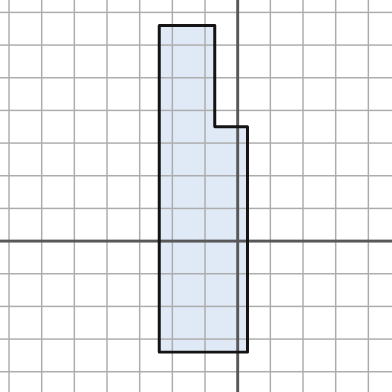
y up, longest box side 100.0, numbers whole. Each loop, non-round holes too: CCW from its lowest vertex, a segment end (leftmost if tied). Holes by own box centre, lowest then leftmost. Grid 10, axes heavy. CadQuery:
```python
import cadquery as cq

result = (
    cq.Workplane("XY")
    .moveTo(-24.0, -34.0)
    .lineTo(3.0, -34.0)
    .lineTo(3.0, 35.0)
    .lineTo(-7.0, 35.0)
    .lineTo(-7.0, 66.0)
    .lineTo(-24.0, 66.0)
    .close()
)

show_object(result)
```